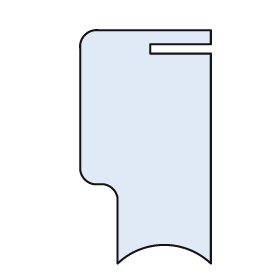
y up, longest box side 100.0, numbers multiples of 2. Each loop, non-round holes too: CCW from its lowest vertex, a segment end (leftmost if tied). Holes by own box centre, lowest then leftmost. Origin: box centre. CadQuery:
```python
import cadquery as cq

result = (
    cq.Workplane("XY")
    .moveTo(-12.0, -50.0)
    .threePointArc((8.0, -42.0), (28.0, -50.0))
    .lineTo(28.0, 40.0)
    .lineTo(2.0, 40.0)
    .lineTo(2.0, 44.0)
    .lineTo(28.0, 44.0)
    .lineTo(28.0, 50.0)
    .lineTo(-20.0, 50.0)
    .threePointArc((-26.0, 48.0), (-28.0, 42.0))
    .lineTo(-28.0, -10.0)
    .threePointArc((-26.0, -14.0), (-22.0, -16.0))
    .lineTo(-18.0, -16.0)
    .threePointArc((-14.0, -18.0), (-12.0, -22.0))
    .close()
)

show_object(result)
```